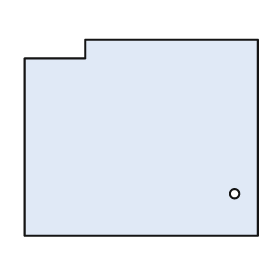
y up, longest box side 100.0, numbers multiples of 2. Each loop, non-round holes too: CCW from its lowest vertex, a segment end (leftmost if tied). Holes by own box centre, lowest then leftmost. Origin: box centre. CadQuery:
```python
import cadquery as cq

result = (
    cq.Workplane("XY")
    .moveTo(-50.0, -42.0)
    .lineTo(50.0, -42.0)
    .lineTo(50.0, 42.0)
    .lineTo(-24.0, 42.0)
    .lineTo(-24.0, 34.0)
    .lineTo(-50.0, 34.0)
    .close()
    .moveTo(40.0, -24.0)
    .circle(2.0)
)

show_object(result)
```